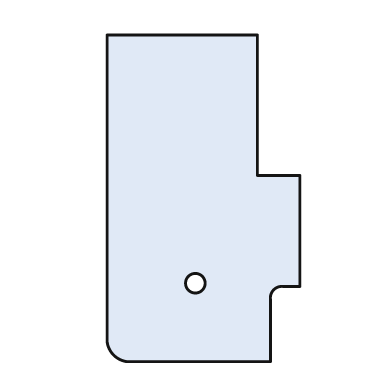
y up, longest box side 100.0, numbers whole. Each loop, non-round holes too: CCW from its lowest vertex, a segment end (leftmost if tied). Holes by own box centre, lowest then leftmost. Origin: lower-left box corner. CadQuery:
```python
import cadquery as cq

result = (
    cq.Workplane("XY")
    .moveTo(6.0, 0.0)
    .lineTo(50.0, 0.0)
    .lineTo(50.0, 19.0)
    .threePointArc((51.0, 22.0), (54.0, 23.0))
    .lineTo(59.0, 23.0)
    .lineTo(59.0, 57.0)
    .lineTo(46.0, 57.0)
    .lineTo(46.0, 100.0)
    .lineTo(0.0, 100.0)
    .lineTo(0.0, 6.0)
    .threePointArc((2.0, 2.0), (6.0, 0.0))
    .close()
    .moveTo(27.0, 24.0)
    .circle(3.0)
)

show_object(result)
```